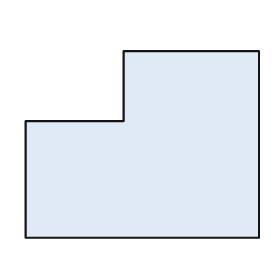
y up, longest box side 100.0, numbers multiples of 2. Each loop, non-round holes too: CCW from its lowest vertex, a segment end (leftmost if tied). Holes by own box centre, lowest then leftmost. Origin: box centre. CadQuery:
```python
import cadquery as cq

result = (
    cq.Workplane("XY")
    .moveTo(-50.0, -40.0)
    .lineTo(50.0, -40.0)
    .lineTo(50.0, 40.0)
    .lineTo(-8.0, 40.0)
    .lineTo(-8.0, 10.0)
    .lineTo(-50.0, 10.0)
    .close()
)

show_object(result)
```